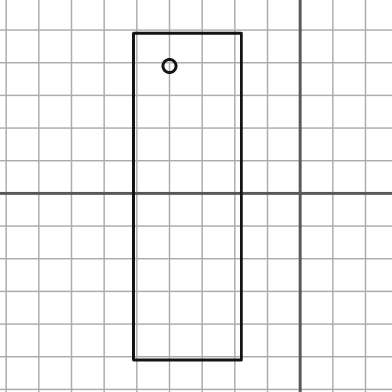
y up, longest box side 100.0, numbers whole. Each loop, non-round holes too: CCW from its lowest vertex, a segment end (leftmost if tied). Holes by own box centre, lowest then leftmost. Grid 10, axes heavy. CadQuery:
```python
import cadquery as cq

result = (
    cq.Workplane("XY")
    .moveTo(-51.0, -51.0)
    .lineTo(-18.0, -51.0)
    .lineTo(-18.0, 49.0)
    .lineTo(-51.0, 49.0)
    .close()
    .moveTo(-40.0, 39.0)
    .circle(2.0)
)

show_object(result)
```